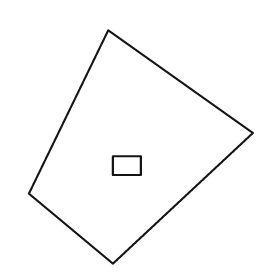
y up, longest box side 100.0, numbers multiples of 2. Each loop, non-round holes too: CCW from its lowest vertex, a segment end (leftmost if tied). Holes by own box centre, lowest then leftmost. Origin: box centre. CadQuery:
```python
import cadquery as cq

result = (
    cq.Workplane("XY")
    .moveTo(-12.0, -50.0)
    .lineTo(48.0, 6.0)
    .lineTo(-14.0, 50.0)
    .lineTo(-48.0, -20.0)
    .close()
    .moveTo(-12.0, -12.0)
    .lineTo(0.0, -12.0)
    .lineTo(0.0, -4.0)
    .lineTo(-12.0, -4.0)
    .close()
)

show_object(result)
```